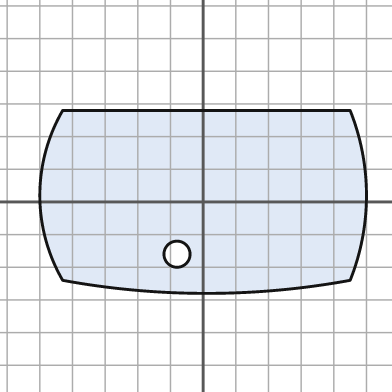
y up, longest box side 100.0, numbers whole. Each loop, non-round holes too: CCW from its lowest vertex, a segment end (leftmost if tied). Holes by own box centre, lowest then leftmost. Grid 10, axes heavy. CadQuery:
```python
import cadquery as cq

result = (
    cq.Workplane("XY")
    .moveTo(-43.0, -24.0)
    .threePointArc((1.0, -28.0), (45.0, -24.0))
    .threePointArc((50.0, 2.0), (45.0, 28.0))
    .lineTo(-43.0, 28.0)
    .threePointArc((-50.0, 2.0), (-43.0, -24.0))
    .close()
    .moveTo(-8.0, -16.0)
    .circle(4.0)
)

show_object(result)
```